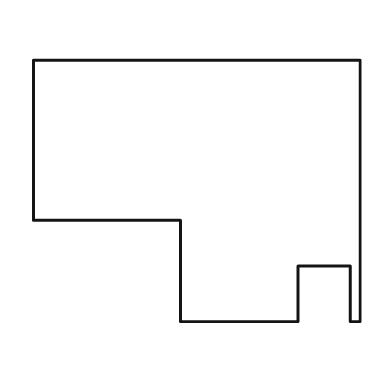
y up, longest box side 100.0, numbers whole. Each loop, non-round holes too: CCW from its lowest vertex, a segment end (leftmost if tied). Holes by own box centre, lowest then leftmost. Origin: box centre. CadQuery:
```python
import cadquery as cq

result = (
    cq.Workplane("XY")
    .moveTo(-5.0, -40.0)
    .lineTo(31.0, -40.0)
    .lineTo(31.0, -23.0)
    .lineTo(47.0, -23.0)
    .lineTo(47.0, -40.0)
    .lineTo(50.0, -40.0)
    .lineTo(50.0, 40.0)
    .lineTo(-50.0, 40.0)
    .lineTo(-50.0, -9.0)
    .lineTo(-5.0, -9.0)
    .close()
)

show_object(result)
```